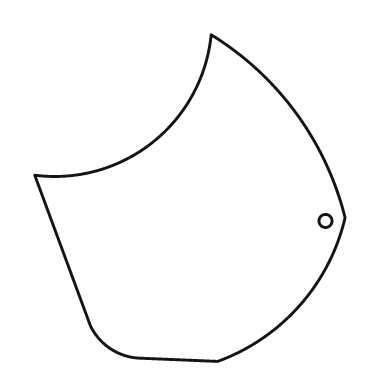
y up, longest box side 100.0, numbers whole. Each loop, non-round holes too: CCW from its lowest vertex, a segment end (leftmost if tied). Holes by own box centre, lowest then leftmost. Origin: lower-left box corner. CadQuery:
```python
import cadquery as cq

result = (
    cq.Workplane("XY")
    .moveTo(56.0, 0.0)
    .threePointArc((81.0, 17.0), (95.0, 44.0))
    .threePointArc((80.0, 76.0), (54.0, 100.0))
    .threePointArc((36.0, 67.0), (0.0, 57.0))
    .lineTo(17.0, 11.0)
    .threePointArc((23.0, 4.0), (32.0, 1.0))
    .close()
    .moveTo(89.0, 43.0)
    .circle(2.0)
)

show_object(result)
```